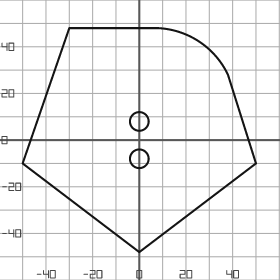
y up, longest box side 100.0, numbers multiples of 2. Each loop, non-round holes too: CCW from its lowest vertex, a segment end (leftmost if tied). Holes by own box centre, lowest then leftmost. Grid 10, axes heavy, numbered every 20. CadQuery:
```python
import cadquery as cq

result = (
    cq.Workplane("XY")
    .moveTo(0.0, -48.0)
    .lineTo(50.0, -10.0)
    .lineTo(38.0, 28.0)
    .threePointArc((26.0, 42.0), (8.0, 48.0))
    .lineTo(-30.0, 48.0)
    .lineTo(-50.0, -10.0)
    .close()
    .moveTo(0.0, -8.0)
    .circle(4.0)
    .moveTo(0.0, 8.0)
    .circle(4.0)
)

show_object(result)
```